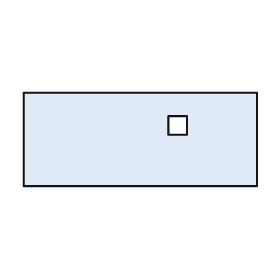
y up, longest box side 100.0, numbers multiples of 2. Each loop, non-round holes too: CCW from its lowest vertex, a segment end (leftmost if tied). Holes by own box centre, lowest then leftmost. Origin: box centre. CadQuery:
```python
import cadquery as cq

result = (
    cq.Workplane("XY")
    .moveTo(-50.0, -20.0)
    .lineTo(50.0, -20.0)
    .lineTo(50.0, 20.0)
    .lineTo(-50.0, 20.0)
    .close()
    .moveTo(12.0, 2.0)
    .lineTo(20.0, 2.0)
    .lineTo(20.0, 10.0)
    .lineTo(12.0, 10.0)
    .close()
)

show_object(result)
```